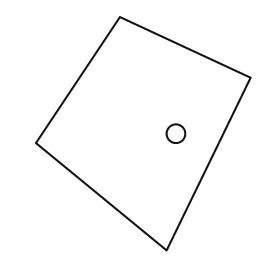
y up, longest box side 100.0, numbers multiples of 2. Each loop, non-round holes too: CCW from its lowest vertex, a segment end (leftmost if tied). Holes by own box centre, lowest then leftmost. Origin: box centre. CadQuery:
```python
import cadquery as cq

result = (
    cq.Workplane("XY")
    .moveTo(10.0, -50.0)
    .lineTo(46.0, 24.0)
    .lineTo(-10.0, 50.0)
    .lineTo(-46.0, -4.0)
    .close()
    .moveTo(14.0, 0.0)
    .circle(4.0)
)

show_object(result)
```